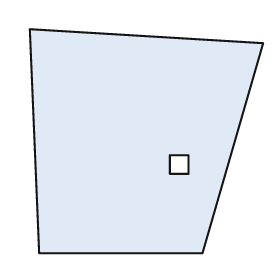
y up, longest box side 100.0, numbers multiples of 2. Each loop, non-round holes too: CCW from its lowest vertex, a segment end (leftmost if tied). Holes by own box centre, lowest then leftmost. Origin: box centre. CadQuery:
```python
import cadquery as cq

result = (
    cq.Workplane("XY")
    .moveTo(-46.0, -48.0)
    .lineTo(24.0, -48.0)
    .lineTo(50.0, 42.0)
    .lineTo(-50.0, 48.0)
    .close()
    .moveTo(10.0, -14.0)
    .lineTo(18.0, -14.0)
    .lineTo(18.0, -6.0)
    .lineTo(10.0, -6.0)
    .close()
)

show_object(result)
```